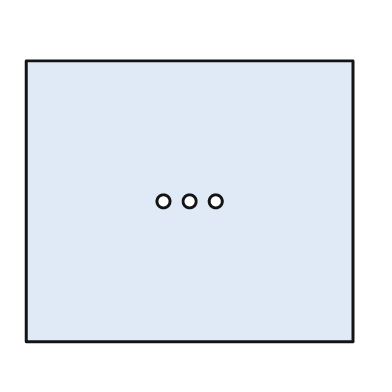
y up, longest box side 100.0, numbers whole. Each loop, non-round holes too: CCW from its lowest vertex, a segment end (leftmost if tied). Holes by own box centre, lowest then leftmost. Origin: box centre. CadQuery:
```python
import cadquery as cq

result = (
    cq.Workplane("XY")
    .moveTo(-50.0, -43.0)
    .lineTo(50.0, -43.0)
    .lineTo(50.0, 43.0)
    .lineTo(-50.0, 43.0)
    .close()
    .moveTo(-8.0, 0.0)
    .circle(2.0)
    .moveTo(0.0, 0.0)
    .circle(2.0)
    .moveTo(8.0, 0.0)
    .circle(2.0)
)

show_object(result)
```